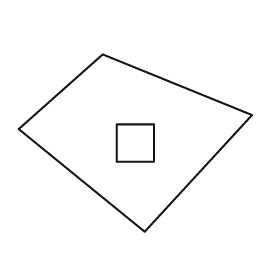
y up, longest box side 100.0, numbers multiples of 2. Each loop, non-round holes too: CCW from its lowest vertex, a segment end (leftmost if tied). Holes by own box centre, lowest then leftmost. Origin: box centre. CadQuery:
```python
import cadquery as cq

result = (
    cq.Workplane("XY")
    .moveTo(4.0, -38.0)
    .lineTo(50.0, 12.0)
    .lineTo(-14.0, 38.0)
    .lineTo(-50.0, 6.0)
    .close()
    .moveTo(-8.0, -8.0)
    .lineTo(8.0, -8.0)
    .lineTo(8.0, 8.0)
    .lineTo(-8.0, 8.0)
    .close()
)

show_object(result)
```